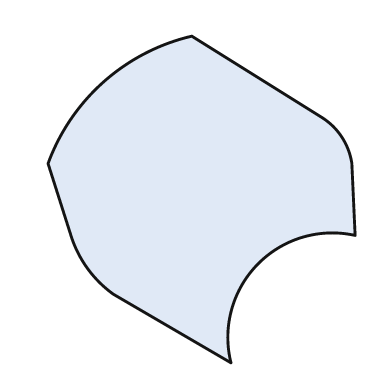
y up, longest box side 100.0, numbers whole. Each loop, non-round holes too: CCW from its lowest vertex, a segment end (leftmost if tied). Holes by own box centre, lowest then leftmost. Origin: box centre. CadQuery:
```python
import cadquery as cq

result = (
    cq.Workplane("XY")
    .moveTo(9.0, -50.0)
    .threePointArc((17.0, -20.0), (47.0, -11.0))
    .lineTo(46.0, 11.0)
    .threePointArc((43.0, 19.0), (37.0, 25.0))
    .lineTo(-3.0, 50.0)
    .threePointArc((-30.0, 36.0), (-47.0, 11.0))
    .lineTo(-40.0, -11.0)
    .threePointArc((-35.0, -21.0), (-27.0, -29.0))
    .close()
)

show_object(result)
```